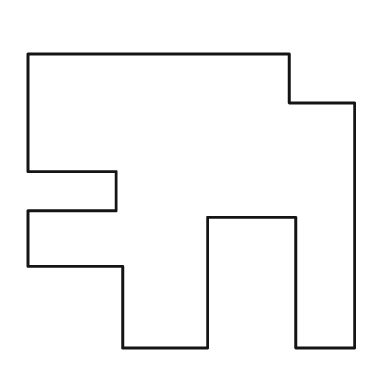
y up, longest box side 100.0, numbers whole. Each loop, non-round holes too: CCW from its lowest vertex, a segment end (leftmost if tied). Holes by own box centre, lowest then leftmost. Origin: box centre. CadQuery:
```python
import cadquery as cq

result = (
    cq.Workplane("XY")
    .moveTo(-21.0, -45.0)
    .lineTo(5.0, -45.0)
    .lineTo(5.0, -5.0)
    .lineTo(32.0, -5.0)
    .lineTo(32.0, -45.0)
    .lineTo(50.0, -45.0)
    .lineTo(50.0, 30.0)
    .lineTo(30.0, 30.0)
    .lineTo(30.0, 45.0)
    .lineTo(-50.0, 45.0)
    .lineTo(-50.0, 9.0)
    .lineTo(-23.0, 9.0)
    .lineTo(-23.0, -3.0)
    .lineTo(-50.0, -3.0)
    .lineTo(-50.0, -20.0)
    .lineTo(-21.0, -20.0)
    .close()
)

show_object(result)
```